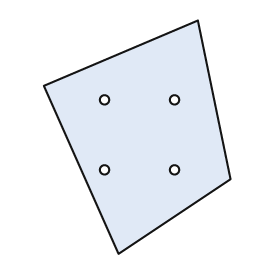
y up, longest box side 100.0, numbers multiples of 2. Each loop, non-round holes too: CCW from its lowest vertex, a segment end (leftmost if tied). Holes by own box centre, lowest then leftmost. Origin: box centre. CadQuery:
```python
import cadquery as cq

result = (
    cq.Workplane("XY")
    .moveTo(-8.0, -50.0)
    .lineTo(40.0, -18.0)
    .lineTo(26.0, 50.0)
    .lineTo(-40.0, 22.0)
    .close()
    .moveTo(-14.0, -14.0)
    .circle(2.0)
    .moveTo(16.0, -14.0)
    .circle(2.0)
    .moveTo(-14.0, 16.0)
    .circle(2.0)
    .moveTo(16.0, 16.0)
    .circle(2.0)
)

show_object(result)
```